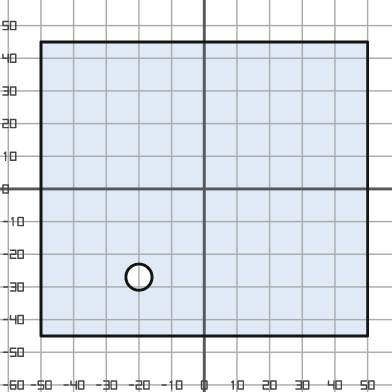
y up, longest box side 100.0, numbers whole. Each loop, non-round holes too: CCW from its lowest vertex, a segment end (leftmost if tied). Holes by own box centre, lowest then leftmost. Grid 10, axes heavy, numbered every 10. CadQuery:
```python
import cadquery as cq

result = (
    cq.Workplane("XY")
    .moveTo(-50.0, -45.0)
    .lineTo(50.0, -45.0)
    .lineTo(50.0, 45.0)
    .lineTo(-50.0, 45.0)
    .close()
    .moveTo(-20.0, -27.0)
    .circle(4.0)
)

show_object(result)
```